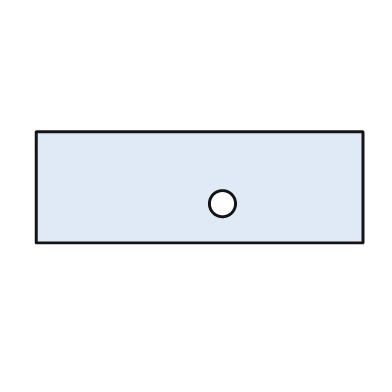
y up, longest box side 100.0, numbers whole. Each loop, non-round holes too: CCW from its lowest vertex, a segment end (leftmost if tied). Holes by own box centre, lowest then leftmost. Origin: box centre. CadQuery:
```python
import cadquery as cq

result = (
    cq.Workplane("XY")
    .moveTo(-50.0, -17.0)
    .lineTo(50.0, -17.0)
    .lineTo(50.0, 17.0)
    .lineTo(-50.0, 17.0)
    .close()
    .moveTo(7.0, -5.0)
    .circle(4.0)
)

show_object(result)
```